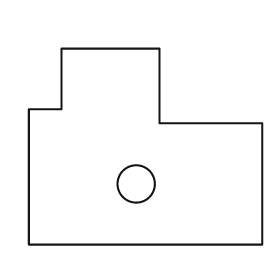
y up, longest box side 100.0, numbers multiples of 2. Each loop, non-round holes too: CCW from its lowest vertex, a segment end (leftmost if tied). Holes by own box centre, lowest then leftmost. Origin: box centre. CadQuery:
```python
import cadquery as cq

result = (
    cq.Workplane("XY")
    .moveTo(-50.0, -42.0)
    .lineTo(50.0, -42.0)
    .lineTo(50.0, 10.0)
    .lineTo(6.0, 10.0)
    .lineTo(6.0, 42.0)
    .lineTo(-36.0, 42.0)
    .lineTo(-36.0, 16.0)
    .lineTo(-50.0, 16.0)
    .close()
    .moveTo(-4.0, -16.0)
    .circle(8.0)
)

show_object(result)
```